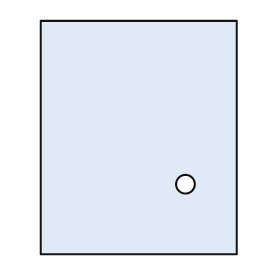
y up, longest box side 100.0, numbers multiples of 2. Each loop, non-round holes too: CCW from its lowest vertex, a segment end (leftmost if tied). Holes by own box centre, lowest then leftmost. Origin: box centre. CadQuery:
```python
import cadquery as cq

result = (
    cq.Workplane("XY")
    .moveTo(-42.0, -50.0)
    .lineTo(42.0, -50.0)
    .lineTo(42.0, 50.0)
    .lineTo(-42.0, 50.0)
    .close()
    .moveTo(20.0, -20.0)
    .circle(4.0)
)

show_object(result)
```